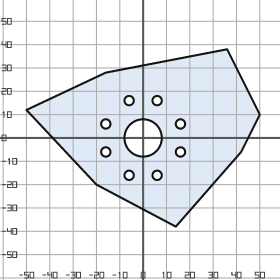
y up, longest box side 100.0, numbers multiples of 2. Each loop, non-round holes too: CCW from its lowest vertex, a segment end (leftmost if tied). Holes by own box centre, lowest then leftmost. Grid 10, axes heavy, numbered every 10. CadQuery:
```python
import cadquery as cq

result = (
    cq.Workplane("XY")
    .moveTo(14.0, -38.0)
    .lineTo(42.0, -6.0)
    .lineTo(50.0, 10.0)
    .lineTo(36.0, 38.0)
    .lineTo(-16.0, 28.0)
    .lineTo(-50.0, 12.0)
    .lineTo(-20.0, -20.0)
    .close()
    .moveTo(-6.0, -16.0)
    .circle(2.0)
    .moveTo(6.0, -16.0)
    .circle(2.0)
    .moveTo(-16.0, -6.0)
    .circle(2.0)
    .moveTo(16.0, -6.0)
    .circle(2.0)
    .moveTo(0.0, 0.0)
    .circle(8.0)
    .moveTo(-16.0, 6.0)
    .circle(2.0)
    .moveTo(16.0, 6.0)
    .circle(2.0)
    .moveTo(-6.0, 16.0)
    .circle(2.0)
    .moveTo(6.0, 16.0)
    .circle(2.0)
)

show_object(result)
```